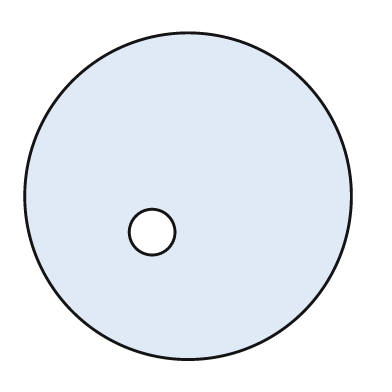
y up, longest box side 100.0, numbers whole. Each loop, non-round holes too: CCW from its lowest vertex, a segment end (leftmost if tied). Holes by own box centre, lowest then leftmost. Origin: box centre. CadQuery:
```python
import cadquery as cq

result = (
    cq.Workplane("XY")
    .moveTo(0.0, 0.0)
    .circle(50.0)
    .moveTo(-11.0, -11.0)
    .circle(7.0)
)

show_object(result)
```